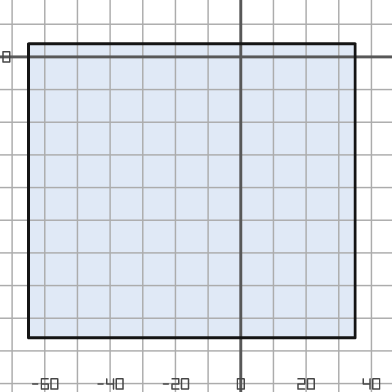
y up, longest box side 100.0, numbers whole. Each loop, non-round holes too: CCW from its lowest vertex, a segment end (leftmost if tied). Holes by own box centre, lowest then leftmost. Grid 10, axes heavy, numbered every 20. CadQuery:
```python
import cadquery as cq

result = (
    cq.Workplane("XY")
    .moveTo(-65.0, -86.0)
    .lineTo(35.0, -86.0)
    .lineTo(35.0, 4.0)
    .lineTo(-65.0, 4.0)
    .close()
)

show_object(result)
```